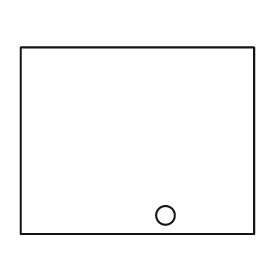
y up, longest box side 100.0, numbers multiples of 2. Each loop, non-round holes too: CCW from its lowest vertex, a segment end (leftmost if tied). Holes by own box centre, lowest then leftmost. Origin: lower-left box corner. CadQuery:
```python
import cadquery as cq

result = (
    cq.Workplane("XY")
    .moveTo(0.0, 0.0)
    .lineTo(100.0, 0.0)
    .lineTo(100.0, 80.0)
    .lineTo(0.0, 80.0)
    .close()
    .moveTo(62.0, 8.0)
    .circle(4.0)
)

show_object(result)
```